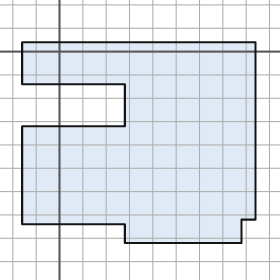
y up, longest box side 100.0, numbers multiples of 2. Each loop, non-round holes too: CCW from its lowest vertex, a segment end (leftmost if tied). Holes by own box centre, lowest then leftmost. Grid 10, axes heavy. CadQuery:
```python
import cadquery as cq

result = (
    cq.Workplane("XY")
    .moveTo(28.0, -82.0)
    .lineTo(78.0, -82.0)
    .lineTo(78.0, -72.0)
    .lineTo(84.0, -72.0)
    .lineTo(84.0, 4.0)
    .lineTo(-16.0, 4.0)
    .lineTo(-16.0, -14.0)
    .lineTo(28.0, -14.0)
    .lineTo(28.0, -32.0)
    .lineTo(-16.0, -32.0)
    .lineTo(-16.0, -74.0)
    .lineTo(28.0, -74.0)
    .close()
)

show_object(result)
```